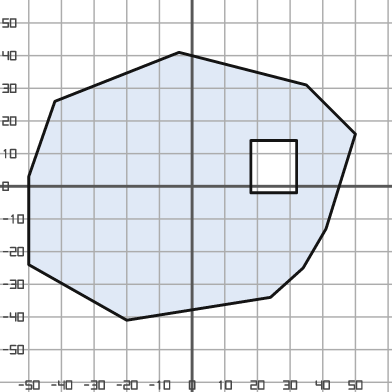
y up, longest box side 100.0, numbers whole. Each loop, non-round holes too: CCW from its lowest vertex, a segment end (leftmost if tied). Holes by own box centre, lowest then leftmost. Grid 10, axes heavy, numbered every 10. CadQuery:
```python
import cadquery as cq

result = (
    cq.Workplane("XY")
    .moveTo(-20.0, -41.0)
    .lineTo(24.0, -34.0)
    .lineTo(34.0, -25.0)
    .lineTo(41.0, -13.0)
    .lineTo(50.0, 16.0)
    .lineTo(35.0, 31.0)
    .lineTo(-4.0, 41.0)
    .lineTo(-42.0, 26.0)
    .lineTo(-50.0, 3.0)
    .lineTo(-50.0, -24.0)
    .close()
    .moveTo(18.0, -2.0)
    .lineTo(32.0, -2.0)
    .lineTo(32.0, 14.0)
    .lineTo(18.0, 14.0)
    .close()
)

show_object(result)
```